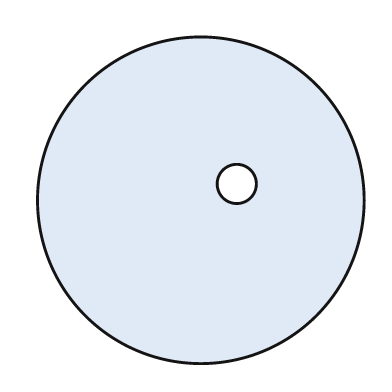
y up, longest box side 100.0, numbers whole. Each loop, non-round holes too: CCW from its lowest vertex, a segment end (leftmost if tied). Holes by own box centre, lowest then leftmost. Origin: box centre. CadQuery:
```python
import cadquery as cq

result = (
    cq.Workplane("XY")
    .moveTo(0.0, 0.0)
    .circle(50.0)
    .moveTo(11.0, 5.0)
    .circle(6.0)
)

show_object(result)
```